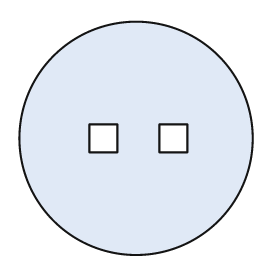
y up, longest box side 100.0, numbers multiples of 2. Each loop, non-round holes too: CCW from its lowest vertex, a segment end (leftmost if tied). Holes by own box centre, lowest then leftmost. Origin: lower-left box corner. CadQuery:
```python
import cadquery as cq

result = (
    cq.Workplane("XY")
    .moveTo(50.0, 50.0)
    .circle(50.0)
    .moveTo(30.0, 44.0)
    .lineTo(42.0, 44.0)
    .lineTo(42.0, 56.0)
    .lineTo(30.0, 56.0)
    .close()
    .moveTo(60.0, 44.0)
    .lineTo(72.0, 44.0)
    .lineTo(72.0, 56.0)
    .lineTo(60.0, 56.0)
    .close()
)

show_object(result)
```